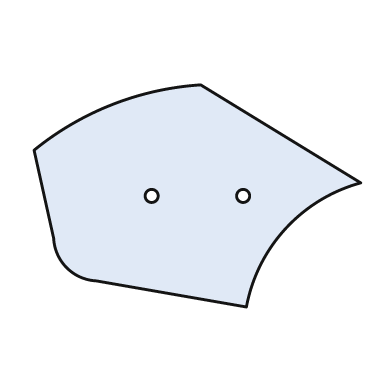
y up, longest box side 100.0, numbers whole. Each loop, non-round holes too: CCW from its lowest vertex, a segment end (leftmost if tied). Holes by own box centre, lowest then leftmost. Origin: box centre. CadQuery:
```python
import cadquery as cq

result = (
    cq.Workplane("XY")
    .moveTo(15.0, -34.0)
    .threePointArc((27.0, -10.0), (50.0, 4.0))
    .lineTo(1.0, 34.0)
    .threePointArc((-26.0, 28.0), (-50.0, 14.0))
    .lineTo(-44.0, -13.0)
    .threePointArc((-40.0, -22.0), (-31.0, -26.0))
    .close()
    .moveTo(-14.0, 0.0)
    .circle(2.0)
    .moveTo(14.0, 0.0)
    .circle(2.0)
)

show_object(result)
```